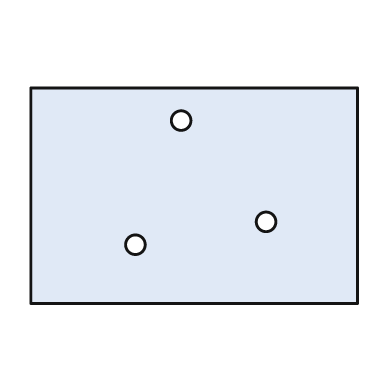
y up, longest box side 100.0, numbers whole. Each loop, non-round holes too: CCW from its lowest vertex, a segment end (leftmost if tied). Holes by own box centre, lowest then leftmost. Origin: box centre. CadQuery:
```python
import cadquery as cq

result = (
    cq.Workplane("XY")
    .moveTo(-50.0, -33.0)
    .lineTo(50.0, -33.0)
    .lineTo(50.0, 33.0)
    .lineTo(-50.0, 33.0)
    .close()
    .moveTo(-18.0, -15.0)
    .circle(3.0)
    .moveTo(22.0, -8.0)
    .circle(3.0)
    .moveTo(-4.0, 23.0)
    .circle(3.0)
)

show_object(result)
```